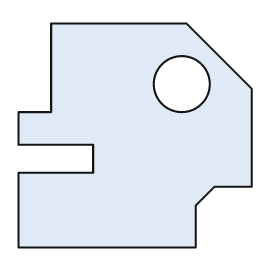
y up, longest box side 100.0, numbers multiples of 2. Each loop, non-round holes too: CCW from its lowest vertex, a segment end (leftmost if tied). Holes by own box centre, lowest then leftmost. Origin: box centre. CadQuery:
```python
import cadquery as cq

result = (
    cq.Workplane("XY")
    .moveTo(-50.0, -48.0)
    .lineTo(26.0, -48.0)
    .lineTo(26.0, -30.0)
    .lineTo(34.0, -22.0)
    .lineTo(50.0, -22.0)
    .lineTo(50.0, 20.0)
    .lineTo(22.0, 48.0)
    .lineTo(-36.0, 48.0)
    .lineTo(-36.0, 10.0)
    .lineTo(-50.0, 10.0)
    .lineTo(-50.0, -4.0)
    .lineTo(-18.0, -4.0)
    .lineTo(-18.0, -16.0)
    .lineTo(-50.0, -16.0)
    .close()
    .moveTo(20.0, 22.0)
    .circle(12.0)
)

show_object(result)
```